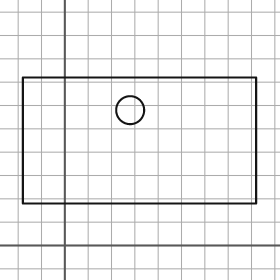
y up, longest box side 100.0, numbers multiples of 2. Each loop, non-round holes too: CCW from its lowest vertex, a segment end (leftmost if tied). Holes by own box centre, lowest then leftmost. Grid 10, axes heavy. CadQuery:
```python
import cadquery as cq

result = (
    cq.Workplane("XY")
    .moveTo(-18.0, 18.0)
    .lineTo(82.0, 18.0)
    .lineTo(82.0, 72.0)
    .lineTo(-18.0, 72.0)
    .close()
    .moveTo(28.0, 58.0)
    .circle(6.0)
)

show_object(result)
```